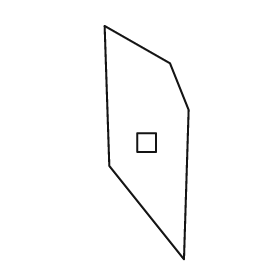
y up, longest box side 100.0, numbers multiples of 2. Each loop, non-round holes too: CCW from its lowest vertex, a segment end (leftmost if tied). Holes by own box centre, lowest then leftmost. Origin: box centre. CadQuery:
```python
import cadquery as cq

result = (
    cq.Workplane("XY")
    .moveTo(16.0, -50.0)
    .lineTo(18.0, 14.0)
    .lineTo(10.0, 34.0)
    .lineTo(-18.0, 50.0)
    .lineTo(-16.0, -10.0)
    .close()
    .moveTo(-4.0, -4.0)
    .lineTo(4.0, -4.0)
    .lineTo(4.0, 4.0)
    .lineTo(-4.0, 4.0)
    .close()
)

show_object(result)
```